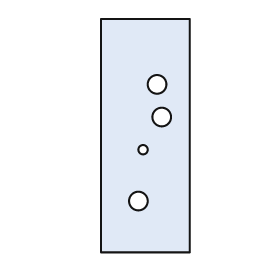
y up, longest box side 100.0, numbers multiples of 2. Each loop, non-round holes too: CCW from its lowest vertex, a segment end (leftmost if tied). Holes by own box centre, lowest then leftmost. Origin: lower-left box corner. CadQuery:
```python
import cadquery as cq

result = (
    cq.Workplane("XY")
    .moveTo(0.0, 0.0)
    .lineTo(38.0, 0.0)
    .lineTo(38.0, 100.0)
    .lineTo(0.0, 100.0)
    .close()
    .moveTo(16.0, 22.0)
    .circle(4.0)
    .moveTo(18.0, 44.0)
    .circle(2.0)
    .moveTo(26.0, 58.0)
    .circle(4.0)
    .moveTo(24.0, 72.0)
    .circle(4.0)
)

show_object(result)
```